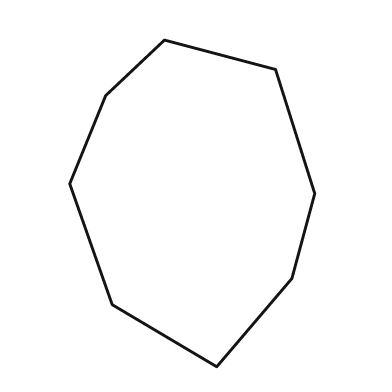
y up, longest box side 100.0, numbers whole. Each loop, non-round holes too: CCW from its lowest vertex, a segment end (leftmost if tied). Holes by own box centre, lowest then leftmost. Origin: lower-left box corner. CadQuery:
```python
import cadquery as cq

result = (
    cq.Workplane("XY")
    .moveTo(45.0, 0.0)
    .lineTo(68.0, 27.0)
    .lineTo(75.0, 53.0)
    .lineTo(63.0, 91.0)
    .lineTo(29.0, 100.0)
    .lineTo(11.0, 83.0)
    .lineTo(0.0, 56.0)
    .lineTo(13.0, 19.0)
    .close()
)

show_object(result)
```